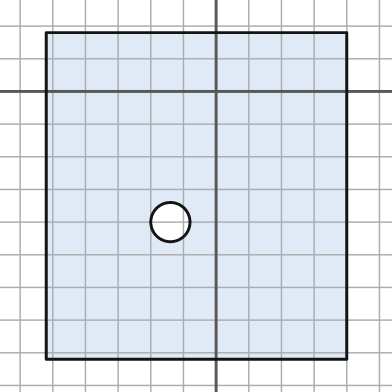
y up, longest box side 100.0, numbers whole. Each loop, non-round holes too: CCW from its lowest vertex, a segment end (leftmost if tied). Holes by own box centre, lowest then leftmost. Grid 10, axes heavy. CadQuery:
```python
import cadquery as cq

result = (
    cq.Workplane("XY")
    .moveTo(-52.0, -82.0)
    .lineTo(40.0, -82.0)
    .lineTo(40.0, 18.0)
    .lineTo(-52.0, 18.0)
    .close()
    .moveTo(-14.0, -40.0)
    .circle(6.0)
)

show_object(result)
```